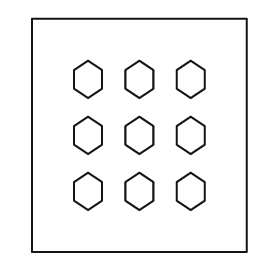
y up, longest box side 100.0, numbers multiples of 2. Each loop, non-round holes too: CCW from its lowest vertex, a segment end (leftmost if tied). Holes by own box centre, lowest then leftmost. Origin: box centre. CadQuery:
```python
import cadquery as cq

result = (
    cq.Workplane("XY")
    .moveTo(-46.0, -50.0)
    .lineTo(46.0, -50.0)
    .lineTo(46.0, 50.0)
    .lineTo(-46.0, 50.0)
    .close()
    .moveTo(-22.0, -32.0)
    .lineTo(-16.0, -28.0)
    .lineTo(-16.0, -20.0)
    .lineTo(-22.0, -16.0)
    .lineTo(-28.0, -20.0)
    .lineTo(-28.0, -28.0)
    .close()
    .moveTo(0.0, -32.0)
    .lineTo(6.0, -28.0)
    .lineTo(6.0, -20.0)
    .lineTo(0.0, -16.0)
    .lineTo(-6.0, -20.0)
    .lineTo(-6.0, -28.0)
    .close()
    .moveTo(22.0, -32.0)
    .lineTo(28.0, -28.0)
    .lineTo(28.0, -20.0)
    .lineTo(22.0, -16.0)
    .lineTo(16.0, -20.0)
    .lineTo(16.0, -28.0)
    .close()
    .moveTo(-22.0, -8.0)
    .lineTo(-16.0, -4.0)
    .lineTo(-16.0, 4.0)
    .lineTo(-22.0, 8.0)
    .lineTo(-28.0, 4.0)
    .lineTo(-28.0, -4.0)
    .close()
    .moveTo(0.0, -8.0)
    .lineTo(6.0, -4.0)
    .lineTo(6.0, 4.0)
    .lineTo(0.0, 8.0)
    .lineTo(-6.0, 4.0)
    .lineTo(-6.0, -4.0)
    .close()
    .moveTo(22.0, -8.0)
    .lineTo(28.0, -4.0)
    .lineTo(28.0, 4.0)
    .lineTo(22.0, 8.0)
    .lineTo(16.0, 4.0)
    .lineTo(16.0, -4.0)
    .close()
    .moveTo(-22.0, 16.0)
    .lineTo(-16.0, 20.0)
    .lineTo(-16.0, 28.0)
    .lineTo(-22.0, 32.0)
    .lineTo(-28.0, 28.0)
    .lineTo(-28.0, 20.0)
    .close()
    .moveTo(0.0, 16.0)
    .lineTo(6.0, 20.0)
    .lineTo(6.0, 28.0)
    .lineTo(0.0, 32.0)
    .lineTo(-6.0, 28.0)
    .lineTo(-6.0, 20.0)
    .close()
    .moveTo(22.0, 16.0)
    .lineTo(28.0, 20.0)
    .lineTo(28.0, 28.0)
    .lineTo(22.0, 32.0)
    .lineTo(16.0, 28.0)
    .lineTo(16.0, 20.0)
    .close()
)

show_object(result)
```